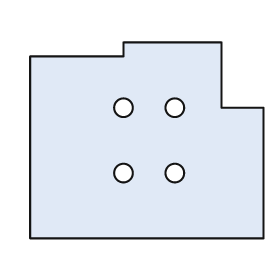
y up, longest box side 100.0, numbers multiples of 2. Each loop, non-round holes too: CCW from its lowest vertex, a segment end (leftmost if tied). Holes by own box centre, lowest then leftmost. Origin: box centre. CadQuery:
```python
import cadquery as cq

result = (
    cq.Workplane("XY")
    .moveTo(-50.0, -42.0)
    .lineTo(50.0, -42.0)
    .lineTo(50.0, 14.0)
    .lineTo(32.0, 14.0)
    .lineTo(32.0, 42.0)
    .lineTo(-10.0, 42.0)
    .lineTo(-10.0, 36.0)
    .lineTo(-50.0, 36.0)
    .close()
    .moveTo(-10.0, -14.0)
    .circle(4.0)
    .moveTo(12.0, -14.0)
    .circle(4.0)
    .moveTo(-10.0, 14.0)
    .circle(4.0)
    .moveTo(12.0, 14.0)
    .circle(4.0)
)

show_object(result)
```